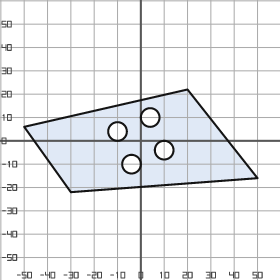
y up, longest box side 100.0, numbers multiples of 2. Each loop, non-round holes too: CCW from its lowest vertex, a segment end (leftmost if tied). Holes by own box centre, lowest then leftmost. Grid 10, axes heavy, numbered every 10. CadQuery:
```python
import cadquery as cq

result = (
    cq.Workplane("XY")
    .moveTo(-30.0, -22.0)
    .lineTo(50.0, -16.0)
    .lineTo(20.0, 22.0)
    .lineTo(-50.0, 6.0)
    .close()
    .moveTo(-4.0, -10.0)
    .circle(4.0)
    .moveTo(10.0, -4.0)
    .circle(4.0)
    .moveTo(-10.0, 4.0)
    .circle(4.0)
    .moveTo(4.0, 10.0)
    .circle(4.0)
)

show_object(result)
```